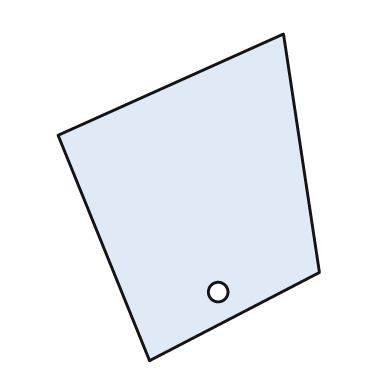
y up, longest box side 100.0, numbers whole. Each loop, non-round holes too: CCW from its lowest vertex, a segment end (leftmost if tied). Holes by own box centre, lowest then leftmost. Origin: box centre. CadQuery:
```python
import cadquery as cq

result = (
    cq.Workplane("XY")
    .moveTo(-12.0, -50.0)
    .lineTo(40.0, -23.0)
    .lineTo(29.0, 50.0)
    .lineTo(-40.0, 19.0)
    .close()
    .moveTo(9.0, -29.0)
    .circle(3.0)
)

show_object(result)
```